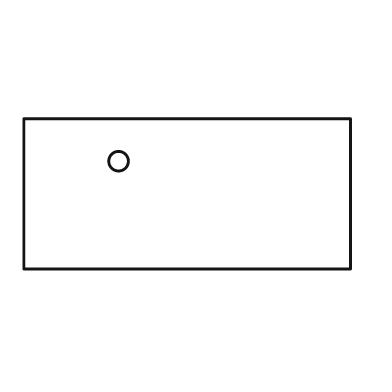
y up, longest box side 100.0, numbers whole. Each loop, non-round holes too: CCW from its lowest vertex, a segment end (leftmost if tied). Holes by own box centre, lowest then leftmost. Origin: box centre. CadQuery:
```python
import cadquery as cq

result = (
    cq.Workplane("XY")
    .moveTo(-50.0, -23.0)
    .lineTo(50.0, -23.0)
    .lineTo(50.0, 23.0)
    .lineTo(-50.0, 23.0)
    .close()
    .moveTo(-21.0, 10.0)
    .circle(3.0)
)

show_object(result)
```